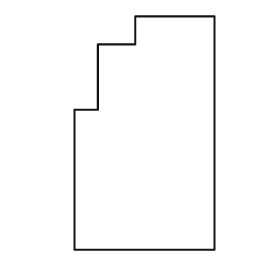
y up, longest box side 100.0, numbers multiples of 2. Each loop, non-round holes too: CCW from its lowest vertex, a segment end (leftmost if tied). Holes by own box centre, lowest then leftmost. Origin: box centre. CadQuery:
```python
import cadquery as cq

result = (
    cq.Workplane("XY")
    .moveTo(-30.0, -50.0)
    .lineTo(30.0, -50.0)
    .lineTo(30.0, 50.0)
    .lineTo(-4.0, 50.0)
    .lineTo(-4.0, 38.0)
    .lineTo(-20.0, 38.0)
    .lineTo(-20.0, 10.0)
    .lineTo(-30.0, 10.0)
    .close()
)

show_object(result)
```